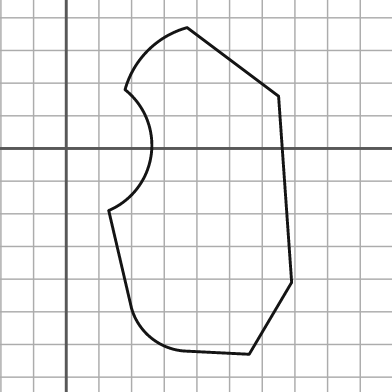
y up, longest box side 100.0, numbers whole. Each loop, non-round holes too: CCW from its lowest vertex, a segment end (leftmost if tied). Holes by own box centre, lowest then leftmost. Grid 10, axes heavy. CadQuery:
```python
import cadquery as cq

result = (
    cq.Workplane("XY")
    .moveTo(56.0, -63.0)
    .lineTo(69.0, -41.0)
    .lineTo(65.0, 16.0)
    .lineTo(37.0, 37.0)
    .threePointArc((25.0, 30.0), (18.0, 18.0))
    .threePointArc((26.0, -2.0), (13.0, -19.0))
    .lineTo(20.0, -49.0)
    .threePointArc((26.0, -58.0), (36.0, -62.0))
    .close()
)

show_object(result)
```